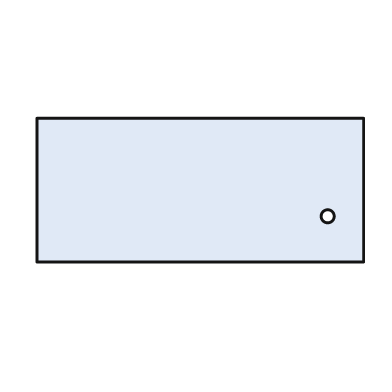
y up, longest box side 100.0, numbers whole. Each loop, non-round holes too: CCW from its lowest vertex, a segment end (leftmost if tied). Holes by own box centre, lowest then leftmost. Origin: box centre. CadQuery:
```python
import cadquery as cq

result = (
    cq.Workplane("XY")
    .moveTo(-50.0, -22.0)
    .lineTo(50.0, -22.0)
    .lineTo(50.0, 22.0)
    .lineTo(-50.0, 22.0)
    .close()
    .moveTo(39.0, -8.0)
    .circle(2.0)
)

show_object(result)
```